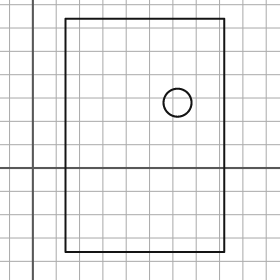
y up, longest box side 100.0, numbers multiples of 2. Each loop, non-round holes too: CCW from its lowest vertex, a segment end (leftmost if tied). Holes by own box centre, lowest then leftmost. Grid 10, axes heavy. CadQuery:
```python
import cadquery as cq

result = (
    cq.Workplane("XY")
    .moveTo(14.0, -36.0)
    .lineTo(82.0, -36.0)
    .lineTo(82.0, 64.0)
    .lineTo(14.0, 64.0)
    .close()
    .moveTo(62.0, 28.0)
    .circle(6.0)
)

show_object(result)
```